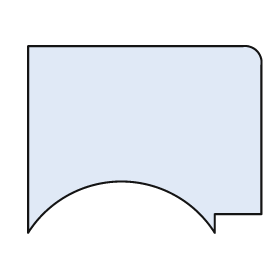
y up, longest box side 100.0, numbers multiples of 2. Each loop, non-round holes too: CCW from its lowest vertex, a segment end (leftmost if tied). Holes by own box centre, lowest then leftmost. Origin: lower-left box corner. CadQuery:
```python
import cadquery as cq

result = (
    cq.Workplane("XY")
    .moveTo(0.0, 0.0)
    .threePointArc((40.0, 22.0), (80.0, 0.0))
    .lineTo(80.0, 8.0)
    .lineTo(100.0, 8.0)
    .lineTo(100.0, 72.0)
    .threePointArc((98.0, 78.0), (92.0, 80.0))
    .lineTo(0.0, 80.0)
    .close()
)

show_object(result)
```